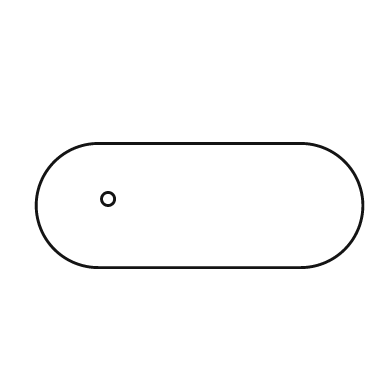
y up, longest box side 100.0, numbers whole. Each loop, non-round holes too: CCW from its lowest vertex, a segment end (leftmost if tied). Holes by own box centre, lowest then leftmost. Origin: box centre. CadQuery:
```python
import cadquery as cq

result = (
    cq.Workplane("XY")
    .moveTo(-31.0, -19.0)
    .lineTo(31.0, -19.0)
    .threePointArc((50.0, 0.0), (31.0, 19.0))
    .lineTo(-31.0, 19.0)
    .threePointArc((-50.0, 0.0), (-31.0, -19.0))
    .close()
    .moveTo(-28.0, 2.0)
    .circle(2.0)
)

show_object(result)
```